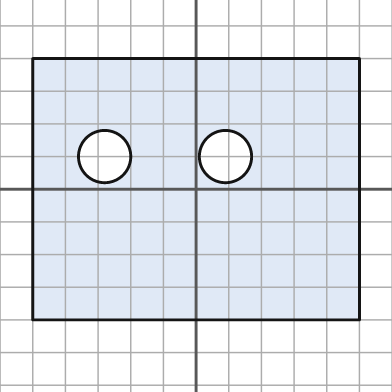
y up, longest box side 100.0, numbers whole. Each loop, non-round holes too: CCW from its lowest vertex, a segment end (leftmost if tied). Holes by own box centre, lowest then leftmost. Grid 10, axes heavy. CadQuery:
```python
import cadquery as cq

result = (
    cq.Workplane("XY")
    .moveTo(-50.0, -40.0)
    .lineTo(50.0, -40.0)
    .lineTo(50.0, 40.0)
    .lineTo(-50.0, 40.0)
    .close()
    .moveTo(-28.0, 10.0)
    .circle(8.0)
    .moveTo(9.0, 10.0)
    .circle(8.0)
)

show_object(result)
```